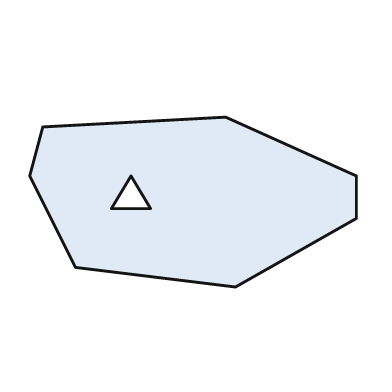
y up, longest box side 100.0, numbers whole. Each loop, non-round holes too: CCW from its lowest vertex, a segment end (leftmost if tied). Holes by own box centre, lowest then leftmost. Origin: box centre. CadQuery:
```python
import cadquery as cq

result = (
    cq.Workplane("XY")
    .moveTo(13.0, -26.0)
    .lineTo(50.0, -5.0)
    .lineTo(50.0, 8.0)
    .lineTo(10.0, 26.0)
    .lineTo(-46.0, 23.0)
    .lineTo(-50.0, 8.0)
    .lineTo(-36.0, -20.0)
    .close()
    .moveTo(-25.0, -2.0)
    .lineTo(-13.0, -2.0)
    .lineTo(-19.0, 8.0)
    .close()
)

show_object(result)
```